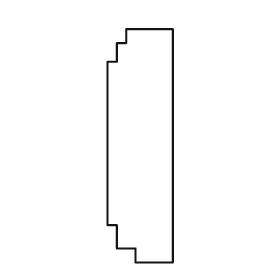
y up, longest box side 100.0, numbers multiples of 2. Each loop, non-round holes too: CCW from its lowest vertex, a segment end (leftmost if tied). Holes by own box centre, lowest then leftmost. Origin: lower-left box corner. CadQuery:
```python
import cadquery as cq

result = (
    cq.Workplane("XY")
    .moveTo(12.0, 0.0)
    .lineTo(28.0, 0.0)
    .lineTo(28.0, 100.0)
    .lineTo(8.0, 100.0)
    .lineTo(8.0, 94.0)
    .lineTo(4.0, 94.0)
    .lineTo(4.0, 86.0)
    .lineTo(0.0, 86.0)
    .lineTo(0.0, 16.0)
    .lineTo(4.0, 16.0)
    .lineTo(4.0, 6.0)
    .lineTo(12.0, 6.0)
    .close()
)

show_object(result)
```